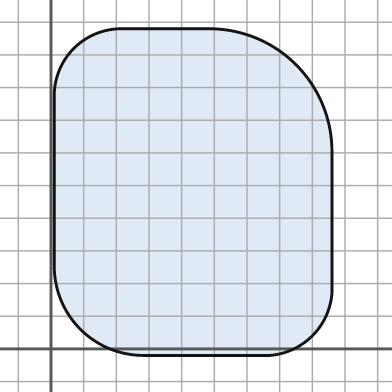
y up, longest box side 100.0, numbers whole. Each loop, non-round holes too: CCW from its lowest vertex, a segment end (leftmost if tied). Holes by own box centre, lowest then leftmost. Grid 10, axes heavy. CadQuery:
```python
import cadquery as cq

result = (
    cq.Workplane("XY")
    .moveTo(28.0, -2.0)
    .lineTo(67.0, -2.0)
    .threePointArc((80.0, 4.0), (86.0, 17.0))
    .lineTo(86.0, 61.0)
    .threePointArc((75.0, 87.0), (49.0, 98.0))
    .lineTo(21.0, 98.0)
    .threePointArc((7.0, 92.0), (1.0, 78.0))
    .lineTo(1.0, 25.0)
    .threePointArc((9.0, 6.0), (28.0, -2.0))
    .close()
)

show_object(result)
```